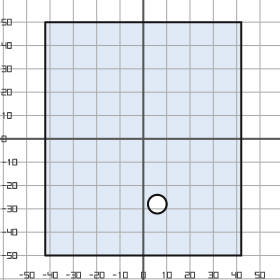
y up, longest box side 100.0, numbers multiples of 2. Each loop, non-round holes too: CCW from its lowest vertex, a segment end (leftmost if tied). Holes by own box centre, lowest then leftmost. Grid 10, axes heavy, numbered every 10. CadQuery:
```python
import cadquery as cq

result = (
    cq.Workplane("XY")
    .moveTo(-42.0, -50.0)
    .lineTo(42.0, -50.0)
    .lineTo(42.0, 50.0)
    .lineTo(-42.0, 50.0)
    .close()
    .moveTo(6.0, -28.0)
    .circle(4.0)
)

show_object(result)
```